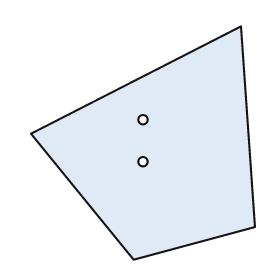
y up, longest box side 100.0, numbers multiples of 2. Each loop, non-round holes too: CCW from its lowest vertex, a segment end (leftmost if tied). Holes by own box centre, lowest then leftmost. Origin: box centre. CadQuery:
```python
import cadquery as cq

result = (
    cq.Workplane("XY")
    .moveTo(-4.0, -50.0)
    .lineTo(48.0, -36.0)
    .lineTo(42.0, 50.0)
    .lineTo(-48.0, 4.0)
    .close()
    .moveTo(0.0, -8.0)
    .circle(2.0)
    .moveTo(0.0, 10.0)
    .circle(2.0)
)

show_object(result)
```